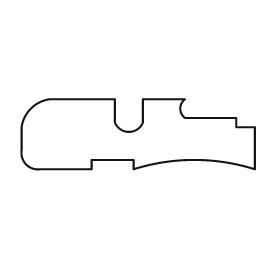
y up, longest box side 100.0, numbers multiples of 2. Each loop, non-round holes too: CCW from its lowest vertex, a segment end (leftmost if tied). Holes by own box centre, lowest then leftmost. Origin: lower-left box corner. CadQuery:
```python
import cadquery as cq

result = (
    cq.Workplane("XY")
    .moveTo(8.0, 0.0)
    .lineTo(30.0, 0.0)
    .lineTo(30.0, 4.0)
    .lineTo(48.0, 4.0)
    .lineTo(48.0, 0.0)
    .threePointArc((74.0, 4.0), (100.0, 0.0))
    .lineTo(100.0, 18.0)
    .lineTo(92.0, 18.0)
    .lineTo(92.0, 22.0)
    .lineTo(70.0, 22.0)
    .threePointArc((68.0, 26.0), (70.0, 30.0))
    .lineTo(52.0, 30.0)
    .lineTo(52.0, 20.0)
    .threePointArc((46.0, 16.0), (40.0, 20.0))
    .lineTo(40.0, 30.0)
    .lineTo(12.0, 30.0)
    .threePointArc((4.0, 26.0), (0.0, 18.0))
    .lineTo(0.0, 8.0)
    .threePointArc((2.0, 2.0), (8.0, 0.0))
    .close()
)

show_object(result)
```